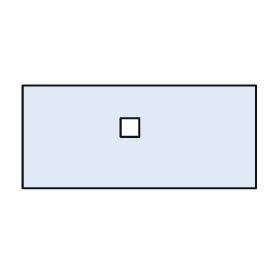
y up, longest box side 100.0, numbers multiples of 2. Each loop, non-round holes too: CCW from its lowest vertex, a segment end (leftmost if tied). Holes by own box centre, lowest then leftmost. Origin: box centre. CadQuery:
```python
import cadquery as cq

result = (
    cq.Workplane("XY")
    .moveTo(-50.0, -22.0)
    .lineTo(50.0, -22.0)
    .lineTo(50.0, 22.0)
    .lineTo(-50.0, 22.0)
    .close()
    .moveTo(-8.0, 0.0)
    .lineTo(0.0, 0.0)
    .lineTo(0.0, 8.0)
    .lineTo(-8.0, 8.0)
    .close()
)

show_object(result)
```